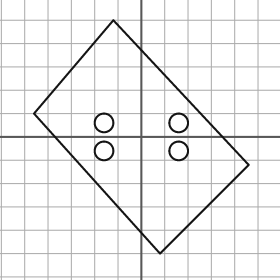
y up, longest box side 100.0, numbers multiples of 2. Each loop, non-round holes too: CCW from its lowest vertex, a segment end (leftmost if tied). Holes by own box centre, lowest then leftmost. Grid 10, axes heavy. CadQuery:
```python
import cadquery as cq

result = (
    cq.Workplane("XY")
    .moveTo(8.0, -50.0)
    .lineTo(46.0, -12.0)
    .lineTo(-12.0, 50.0)
    .lineTo(-46.0, 10.0)
    .close()
    .moveTo(-16.0, -6.0)
    .circle(4.0)
    .moveTo(16.0, -6.0)
    .circle(4.0)
    .moveTo(-16.0, 6.0)
    .circle(4.0)
    .moveTo(16.0, 6.0)
    .circle(4.0)
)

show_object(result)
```